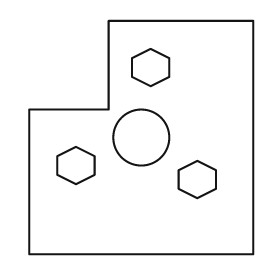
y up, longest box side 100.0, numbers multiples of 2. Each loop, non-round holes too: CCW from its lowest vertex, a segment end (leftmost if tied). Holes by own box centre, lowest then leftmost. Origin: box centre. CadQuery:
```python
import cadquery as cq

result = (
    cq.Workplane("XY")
    .moveTo(-48.0, -50.0)
    .lineTo(48.0, -50.0)
    .lineTo(48.0, 50.0)
    .lineTo(-14.0, 50.0)
    .lineTo(-14.0, 12.0)
    .lineTo(-48.0, 12.0)
    .close()
    .moveTo(24.0, -26.0)
    .lineTo(32.0, -22.0)
    .lineTo(32.0, -14.0)
    .lineTo(24.0, -10.0)
    .lineTo(16.0, -14.0)
    .lineTo(16.0, -22.0)
    .close()
    .moveTo(-28.0, -20.0)
    .lineTo(-20.0, -16.0)
    .lineTo(-20.0, -8.0)
    .lineTo(-28.0, -4.0)
    .lineTo(-36.0, -8.0)
    .lineTo(-36.0, -16.0)
    .close()
    .moveTo(0.0, 0.0)
    .circle(12.0)
    .moveTo(4.0, 22.0)
    .lineTo(12.0, 26.0)
    .lineTo(12.0, 34.0)
    .lineTo(4.0, 38.0)
    .lineTo(-4.0, 34.0)
    .lineTo(-4.0, 26.0)
    .close()
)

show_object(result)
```